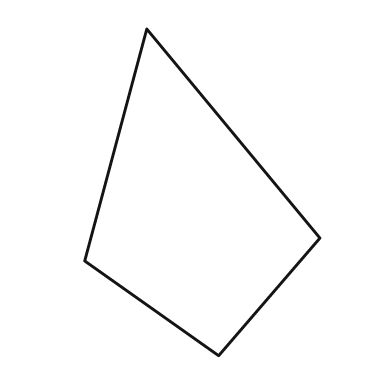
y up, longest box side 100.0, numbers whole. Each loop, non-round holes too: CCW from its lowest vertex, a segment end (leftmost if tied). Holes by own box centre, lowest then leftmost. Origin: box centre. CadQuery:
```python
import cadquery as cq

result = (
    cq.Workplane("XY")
    .moveTo(5.0, -50.0)
    .lineTo(36.0, -14.0)
    .lineTo(-17.0, 50.0)
    .lineTo(-36.0, -21.0)
    .close()
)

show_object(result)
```